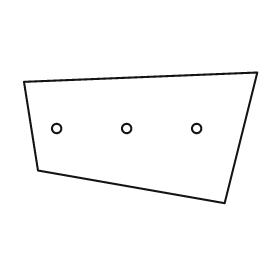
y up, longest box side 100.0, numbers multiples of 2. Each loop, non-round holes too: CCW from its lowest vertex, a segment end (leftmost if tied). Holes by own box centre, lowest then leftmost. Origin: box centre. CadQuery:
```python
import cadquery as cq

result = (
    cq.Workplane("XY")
    .moveTo(36.0, -28.0)
    .lineTo(50.0, 28.0)
    .lineTo(-50.0, 24.0)
    .lineTo(-44.0, -14.0)
    .close()
    .moveTo(-36.0, 4.0)
    .circle(2.0)
    .moveTo(-6.0, 4.0)
    .circle(2.0)
    .moveTo(24.0, 4.0)
    .circle(2.0)
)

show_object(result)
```